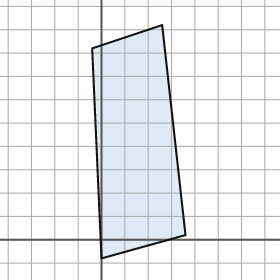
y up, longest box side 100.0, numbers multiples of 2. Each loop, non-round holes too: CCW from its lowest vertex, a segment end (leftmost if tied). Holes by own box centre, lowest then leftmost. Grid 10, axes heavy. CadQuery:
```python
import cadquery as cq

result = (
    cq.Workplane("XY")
    .moveTo(0.0, -8.0)
    .lineTo(36.0, 2.0)
    .lineTo(26.0, 92.0)
    .lineTo(-4.0, 82.0)
    .close()
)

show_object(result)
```